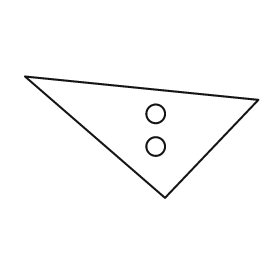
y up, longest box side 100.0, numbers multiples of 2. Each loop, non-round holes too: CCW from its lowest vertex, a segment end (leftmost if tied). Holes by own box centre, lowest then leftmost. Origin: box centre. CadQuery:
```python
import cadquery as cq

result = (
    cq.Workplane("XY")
    .moveTo(10.0, -26.0)
    .lineTo(50.0, 16.0)
    .lineTo(-50.0, 26.0)
    .close()
    .moveTo(6.0, -4.0)
    .circle(4.0)
    .moveTo(6.0, 10.0)
    .circle(4.0)
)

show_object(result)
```